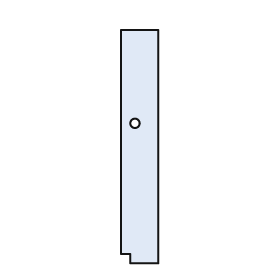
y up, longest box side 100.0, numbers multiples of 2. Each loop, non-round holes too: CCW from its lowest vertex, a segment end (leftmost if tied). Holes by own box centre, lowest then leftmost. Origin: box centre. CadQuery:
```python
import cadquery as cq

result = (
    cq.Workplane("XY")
    .moveTo(-4.0, -50.0)
    .lineTo(8.0, -50.0)
    .lineTo(8.0, 50.0)
    .lineTo(-8.0, 50.0)
    .lineTo(-8.0, -46.0)
    .lineTo(-4.0, -46.0)
    .close()
    .moveTo(-2.0, 10.0)
    .circle(2.0)
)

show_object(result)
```